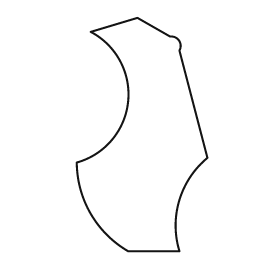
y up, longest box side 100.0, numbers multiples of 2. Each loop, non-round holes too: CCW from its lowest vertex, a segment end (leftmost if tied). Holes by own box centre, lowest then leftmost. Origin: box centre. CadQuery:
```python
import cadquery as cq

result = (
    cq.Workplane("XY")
    .moveTo(-6.0, -50.0)
    .lineTo(16.0, -50.0)
    .threePointArc((16.0, -28.0), (28.0, -10.0))
    .lineTo(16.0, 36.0)
    .threePointArc((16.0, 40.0), (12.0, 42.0))
    .lineTo(-2.0, 50.0)
    .lineTo(-22.0, 44.0)
    .threePointArc((-6.0, 14.0), (-28.0, -12.0))
    .threePointArc((-22.0, -34.0), (-6.0, -50.0))
    .close()
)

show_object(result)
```